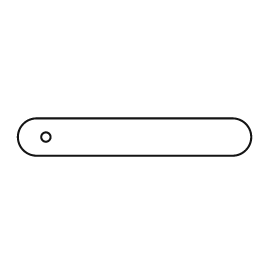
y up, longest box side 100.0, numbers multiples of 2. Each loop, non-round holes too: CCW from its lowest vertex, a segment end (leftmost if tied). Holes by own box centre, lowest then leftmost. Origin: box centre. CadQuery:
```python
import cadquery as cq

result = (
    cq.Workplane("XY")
    .moveTo(-42.0, -8.0)
    .lineTo(42.0, -8.0)
    .threePointArc((50.0, 0.0), (42.0, 8.0))
    .lineTo(-42.0, 8.0)
    .threePointArc((-50.0, 0.0), (-42.0, -8.0))
    .close()
    .moveTo(-38.0, 0.0)
    .circle(2.0)
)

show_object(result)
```